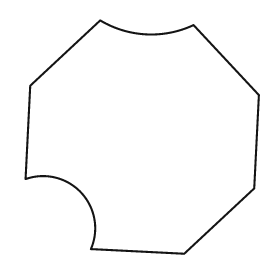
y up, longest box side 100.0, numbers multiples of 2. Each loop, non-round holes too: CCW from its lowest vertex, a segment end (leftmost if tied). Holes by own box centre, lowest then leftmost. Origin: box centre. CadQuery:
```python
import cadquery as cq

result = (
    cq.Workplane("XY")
    .moveTo(18.0, -50.0)
    .lineTo(48.0, -22.0)
    .lineTo(50.0, 18.0)
    .lineTo(22.0, 48.0)
    .threePointArc((2.0, 44.0), (-18.0, 50.0))
    .lineTo(-48.0, 22.0)
    .lineTo(-50.0, -18.0)
    .threePointArc((-26.0, -24.0), (-22.0, -48.0))
    .close()
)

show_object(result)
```